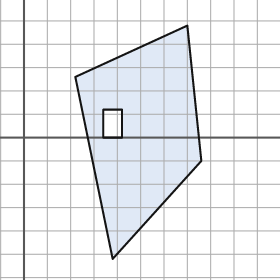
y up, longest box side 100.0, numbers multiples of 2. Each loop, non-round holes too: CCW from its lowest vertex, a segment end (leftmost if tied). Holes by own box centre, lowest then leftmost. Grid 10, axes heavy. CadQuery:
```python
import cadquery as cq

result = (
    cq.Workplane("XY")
    .moveTo(38.0, -52.0)
    .lineTo(76.0, -10.0)
    .lineTo(70.0, 48.0)
    .lineTo(22.0, 26.0)
    .close()
    .moveTo(34.0, 0.0)
    .lineTo(42.0, 0.0)
    .lineTo(42.0, 12.0)
    .lineTo(34.0, 12.0)
    .close()
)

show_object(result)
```